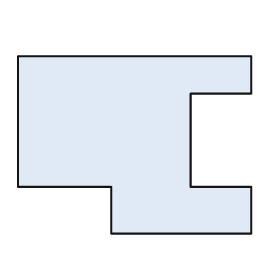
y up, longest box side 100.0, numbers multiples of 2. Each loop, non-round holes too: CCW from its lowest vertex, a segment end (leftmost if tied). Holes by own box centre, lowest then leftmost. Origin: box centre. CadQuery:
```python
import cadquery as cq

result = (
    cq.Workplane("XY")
    .moveTo(-10.0, -38.0)
    .lineTo(50.0, -38.0)
    .lineTo(50.0, -18.0)
    .lineTo(24.0, -18.0)
    .lineTo(24.0, 22.0)
    .lineTo(50.0, 22.0)
    .lineTo(50.0, 38.0)
    .lineTo(-50.0, 38.0)
    .lineTo(-50.0, -18.0)
    .lineTo(-10.0, -18.0)
    .close()
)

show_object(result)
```